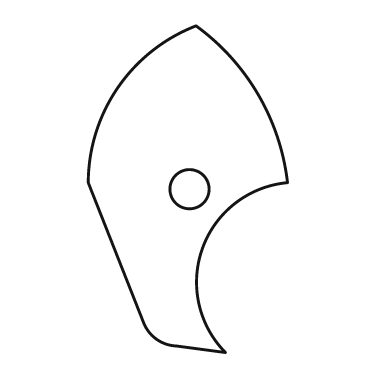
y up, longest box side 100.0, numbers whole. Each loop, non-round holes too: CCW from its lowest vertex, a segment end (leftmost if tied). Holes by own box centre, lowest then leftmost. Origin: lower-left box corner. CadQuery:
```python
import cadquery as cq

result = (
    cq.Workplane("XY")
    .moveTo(42.0, 0.0)
    .threePointArc((35.0, 32.0), (61.0, 52.0))
    .threePointArc((52.0, 79.0), (33.0, 100.0))
    .threePointArc((9.0, 81.0), (0.0, 52.0))
    .lineTo(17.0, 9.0)
    .threePointArc((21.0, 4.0), (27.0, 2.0))
    .close()
    .moveTo(31.0, 50.0)
    .circle(6.0)
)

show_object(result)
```